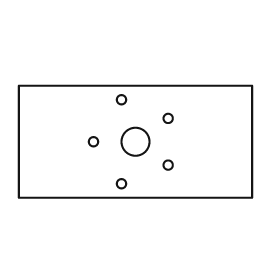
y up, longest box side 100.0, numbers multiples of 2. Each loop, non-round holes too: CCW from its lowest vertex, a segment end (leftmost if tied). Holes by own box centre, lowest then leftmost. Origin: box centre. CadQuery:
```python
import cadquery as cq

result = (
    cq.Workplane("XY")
    .moveTo(-50.0, -24.0)
    .lineTo(50.0, -24.0)
    .lineTo(50.0, 24.0)
    .lineTo(-50.0, 24.0)
    .close()
    .moveTo(-6.0, -18.0)
    .circle(2.0)
    .moveTo(14.0, -10.0)
    .circle(2.0)
    .moveTo(-18.0, 0.0)
    .circle(2.0)
    .moveTo(0.0, 0.0)
    .circle(6.0)
    .moveTo(14.0, 10.0)
    .circle(2.0)
    .moveTo(-6.0, 18.0)
    .circle(2.0)
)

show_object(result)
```